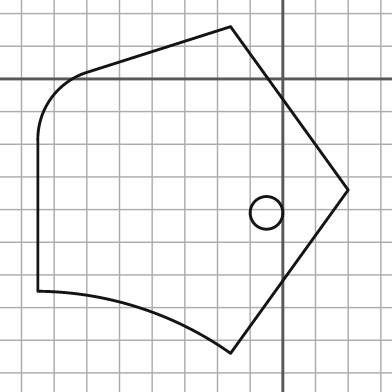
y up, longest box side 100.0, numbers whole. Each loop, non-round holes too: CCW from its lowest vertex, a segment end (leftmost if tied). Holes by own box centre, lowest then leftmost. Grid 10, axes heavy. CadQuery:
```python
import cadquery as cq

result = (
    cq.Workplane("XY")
    .moveTo(-16.0, -84.0)
    .lineTo(20.0, -34.0)
    .lineTo(-16.0, 16.0)
    .lineTo(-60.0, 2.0)
    .threePointArc((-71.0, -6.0), (-75.0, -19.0))
    .lineTo(-75.0, -65.0)
    .threePointArc((-44.0, -70.0), (-16.0, -84.0))
    .close()
    .moveTo(-5.0, -41.0)
    .circle(5.0)
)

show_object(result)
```